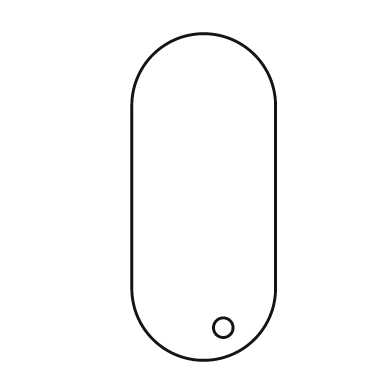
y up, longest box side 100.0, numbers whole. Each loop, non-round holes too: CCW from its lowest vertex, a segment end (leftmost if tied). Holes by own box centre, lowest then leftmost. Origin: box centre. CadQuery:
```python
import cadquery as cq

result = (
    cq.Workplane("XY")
    .moveTo(-22.0, -28.0)
    .threePointArc((0.0, -50.0), (22.0, -28.0))
    .lineTo(22.0, 28.0)
    .threePointArc((0.0, 50.0), (-22.0, 28.0))
    .close()
    .moveTo(6.0, -40.0)
    .circle(3.0)
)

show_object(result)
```